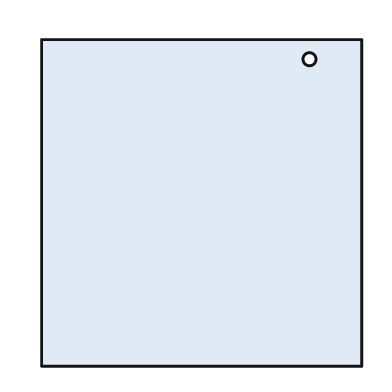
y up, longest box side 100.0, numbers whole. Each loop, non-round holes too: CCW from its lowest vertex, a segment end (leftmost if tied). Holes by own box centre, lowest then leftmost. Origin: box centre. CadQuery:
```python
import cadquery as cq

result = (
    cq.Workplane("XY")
    .moveTo(-49.0, -50.0)
    .lineTo(49.0, -50.0)
    .lineTo(49.0, 50.0)
    .lineTo(-49.0, 50.0)
    .close()
    .moveTo(33.0, 44.0)
    .circle(2.0)
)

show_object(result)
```